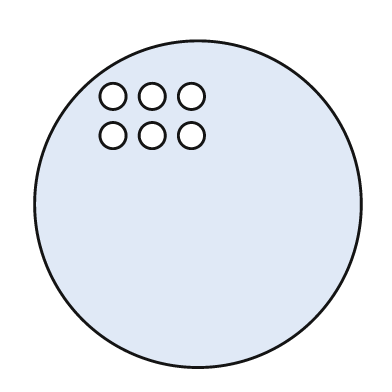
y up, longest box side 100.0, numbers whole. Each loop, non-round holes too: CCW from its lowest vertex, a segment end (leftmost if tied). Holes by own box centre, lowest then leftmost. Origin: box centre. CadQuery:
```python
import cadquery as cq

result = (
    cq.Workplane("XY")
    .moveTo(0.0, 0.0)
    .circle(50.0)
    .moveTo(-26.0, 21.0)
    .circle(4.0)
    .moveTo(-14.0, 21.0)
    .circle(4.0)
    .moveTo(-2.0, 21.0)
    .circle(4.0)
    .moveTo(-26.0, 33.0)
    .circle(4.0)
    .moveTo(-14.0, 33.0)
    .circle(4.0)
    .moveTo(-2.0, 33.0)
    .circle(4.0)
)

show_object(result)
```